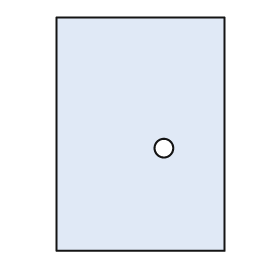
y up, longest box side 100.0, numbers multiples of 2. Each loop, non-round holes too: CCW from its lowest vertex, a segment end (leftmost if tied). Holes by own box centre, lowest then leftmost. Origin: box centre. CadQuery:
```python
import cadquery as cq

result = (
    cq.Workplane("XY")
    .moveTo(-36.0, -50.0)
    .lineTo(36.0, -50.0)
    .lineTo(36.0, 50.0)
    .lineTo(-36.0, 50.0)
    .close()
    .moveTo(10.0, -6.0)
    .circle(4.0)
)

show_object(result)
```